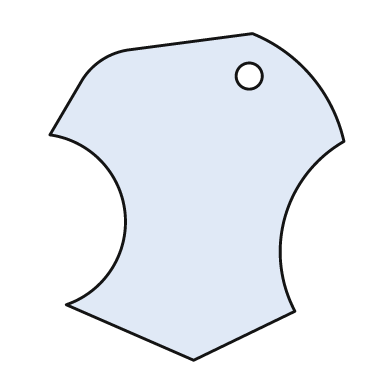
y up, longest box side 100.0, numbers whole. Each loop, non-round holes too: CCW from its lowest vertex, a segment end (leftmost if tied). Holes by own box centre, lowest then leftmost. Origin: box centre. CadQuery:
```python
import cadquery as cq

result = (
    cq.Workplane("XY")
    .moveTo(-1.0, -50.0)
    .lineTo(30.0, -35.0)
    .threePointArc((27.0, -6.0), (45.0, 17.0))
    .threePointArc((35.0, 37.0), (17.0, 50.0))
    .lineTo(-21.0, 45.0)
    .threePointArc((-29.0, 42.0), (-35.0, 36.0))
    .lineTo(-45.0, 19.0)
    .threePointArc((-22.0, -5.0), (-40.0, -33.0))
    .close()
    .moveTo(16.0, 37.0)
    .circle(4.0)
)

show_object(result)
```